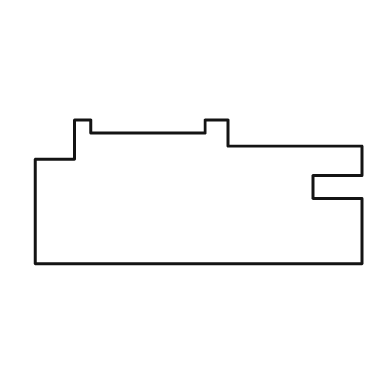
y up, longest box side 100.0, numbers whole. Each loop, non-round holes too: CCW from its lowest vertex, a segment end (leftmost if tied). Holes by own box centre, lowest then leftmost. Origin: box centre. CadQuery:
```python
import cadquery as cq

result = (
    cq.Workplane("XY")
    .moveTo(-50.0, -22.0)
    .lineTo(50.0, -22.0)
    .lineTo(50.0, -2.0)
    .lineTo(35.0, -2.0)
    .lineTo(35.0, 5.0)
    .lineTo(50.0, 5.0)
    .lineTo(50.0, 14.0)
    .lineTo(9.0, 14.0)
    .lineTo(9.0, 22.0)
    .lineTo(2.0, 22.0)
    .lineTo(2.0, 18.0)
    .lineTo(-33.0, 18.0)
    .lineTo(-33.0, 22.0)
    .lineTo(-38.0, 22.0)
    .lineTo(-38.0, 10.0)
    .lineTo(-50.0, 10.0)
    .close()
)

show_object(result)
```